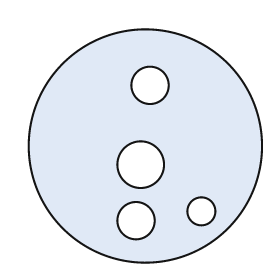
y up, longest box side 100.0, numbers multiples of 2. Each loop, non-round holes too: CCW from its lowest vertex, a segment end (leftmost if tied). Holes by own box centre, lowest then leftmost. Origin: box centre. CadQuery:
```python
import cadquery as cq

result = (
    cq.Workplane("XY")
    .moveTo(0.0, 0.0)
    .circle(50.0)
    .moveTo(-4.0, -32.0)
    .circle(8.0)
    .moveTo(24.0, -28.0)
    .circle(6.0)
    .moveTo(-2.0, -8.0)
    .circle(10.0)
    .moveTo(2.0, 26.0)
    .circle(8.0)
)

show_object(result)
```